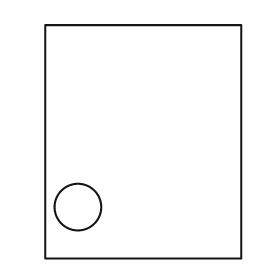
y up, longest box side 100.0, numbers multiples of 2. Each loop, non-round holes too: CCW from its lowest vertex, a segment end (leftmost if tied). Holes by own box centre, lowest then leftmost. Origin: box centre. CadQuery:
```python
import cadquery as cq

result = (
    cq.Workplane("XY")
    .moveTo(-42.0, -50.0)
    .lineTo(42.0, -50.0)
    .lineTo(42.0, 50.0)
    .lineTo(-42.0, 50.0)
    .close()
    .moveTo(-28.0, -28.0)
    .circle(10.0)
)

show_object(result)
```